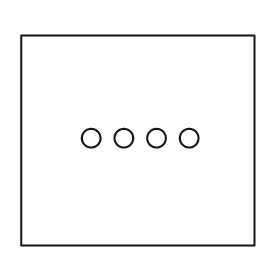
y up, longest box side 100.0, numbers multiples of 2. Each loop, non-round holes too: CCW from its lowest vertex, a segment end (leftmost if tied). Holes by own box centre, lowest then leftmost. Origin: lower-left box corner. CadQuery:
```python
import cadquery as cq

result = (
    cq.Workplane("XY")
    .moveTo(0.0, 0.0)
    .lineTo(100.0, 0.0)
    .lineTo(100.0, 90.0)
    .lineTo(0.0, 90.0)
    .close()
    .moveTo(30.0, 46.0)
    .circle(4.0)
    .moveTo(44.0, 46.0)
    .circle(4.0)
    .moveTo(58.0, 46.0)
    .circle(4.0)
    .moveTo(72.0, 46.0)
    .circle(4.0)
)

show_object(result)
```